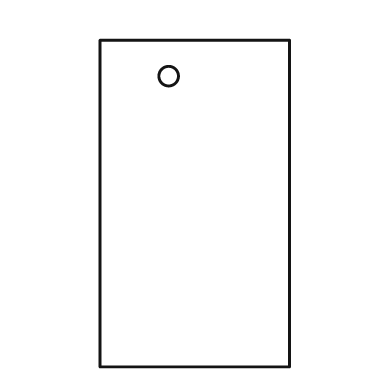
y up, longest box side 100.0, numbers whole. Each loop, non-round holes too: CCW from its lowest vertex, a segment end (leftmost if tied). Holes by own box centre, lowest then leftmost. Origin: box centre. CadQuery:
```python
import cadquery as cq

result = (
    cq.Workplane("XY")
    .moveTo(-29.0, -50.0)
    .lineTo(29.0, -50.0)
    .lineTo(29.0, 50.0)
    .lineTo(-29.0, 50.0)
    .close()
    .moveTo(-8.0, 39.0)
    .circle(3.0)
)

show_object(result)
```